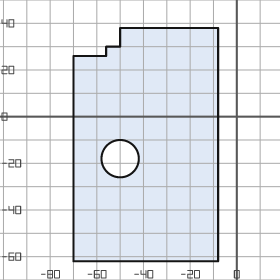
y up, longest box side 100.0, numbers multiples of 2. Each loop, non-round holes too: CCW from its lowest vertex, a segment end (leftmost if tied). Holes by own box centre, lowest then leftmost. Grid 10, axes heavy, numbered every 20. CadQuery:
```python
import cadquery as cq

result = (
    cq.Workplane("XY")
    .moveTo(-70.0, -62.0)
    .lineTo(-8.0, -62.0)
    .lineTo(-8.0, 38.0)
    .lineTo(-50.0, 38.0)
    .lineTo(-50.0, 30.0)
    .lineTo(-56.0, 30.0)
    .lineTo(-56.0, 26.0)
    .lineTo(-70.0, 26.0)
    .close()
    .moveTo(-50.0, -18.0)
    .circle(8.0)
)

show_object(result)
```